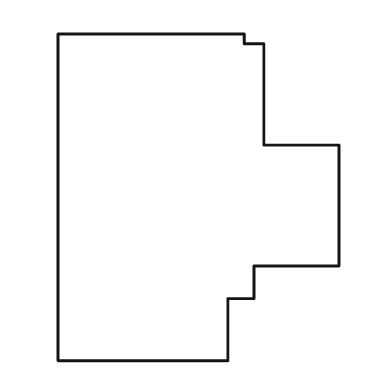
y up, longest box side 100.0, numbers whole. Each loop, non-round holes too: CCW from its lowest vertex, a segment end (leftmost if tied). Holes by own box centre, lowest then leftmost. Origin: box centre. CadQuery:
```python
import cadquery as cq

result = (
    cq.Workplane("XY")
    .moveTo(-43.0, -50.0)
    .lineTo(9.0, -50.0)
    .lineTo(9.0, -31.0)
    .lineTo(17.0, -31.0)
    .lineTo(17.0, -21.0)
    .lineTo(43.0, -21.0)
    .lineTo(43.0, 16.0)
    .lineTo(20.0, 16.0)
    .lineTo(20.0, 47.0)
    .lineTo(14.0, 47.0)
    .lineTo(14.0, 50.0)
    .lineTo(-43.0, 50.0)
    .close()
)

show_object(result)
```